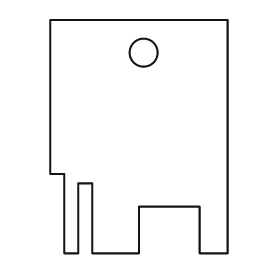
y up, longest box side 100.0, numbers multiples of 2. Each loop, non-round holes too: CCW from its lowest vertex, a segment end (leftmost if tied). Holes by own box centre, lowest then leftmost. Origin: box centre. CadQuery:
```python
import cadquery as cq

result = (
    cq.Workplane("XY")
    .moveTo(-32.0, -50.0)
    .lineTo(-26.0, -50.0)
    .lineTo(-26.0, -20.0)
    .lineTo(-20.0, -20.0)
    .lineTo(-20.0, -50.0)
    .lineTo(0.0, -50.0)
    .lineTo(0.0, -30.0)
    .lineTo(26.0, -30.0)
    .lineTo(26.0, -50.0)
    .lineTo(38.0, -50.0)
    .lineTo(38.0, 50.0)
    .lineTo(-38.0, 50.0)
    .lineTo(-38.0, -16.0)
    .lineTo(-32.0, -16.0)
    .close()
    .moveTo(2.0, 36.0)
    .circle(6.0)
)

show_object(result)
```